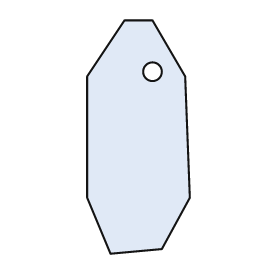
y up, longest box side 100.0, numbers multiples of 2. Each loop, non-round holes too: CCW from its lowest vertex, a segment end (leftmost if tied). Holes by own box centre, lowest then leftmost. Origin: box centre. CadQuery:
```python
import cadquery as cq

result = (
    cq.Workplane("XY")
    .moveTo(-12.0, -50.0)
    .lineTo(10.0, -48.0)
    .lineTo(22.0, -26.0)
    .lineTo(20.0, 26.0)
    .lineTo(6.0, 50.0)
    .lineTo(-6.0, 50.0)
    .lineTo(-22.0, 26.0)
    .lineTo(-22.0, -26.0)
    .close()
    .moveTo(6.0, 28.0)
    .circle(4.0)
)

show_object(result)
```